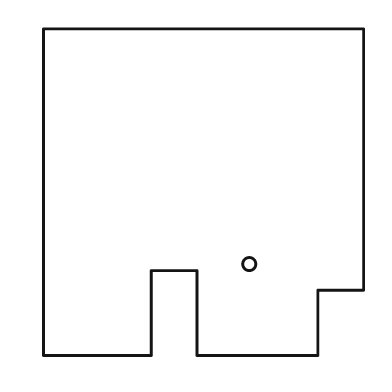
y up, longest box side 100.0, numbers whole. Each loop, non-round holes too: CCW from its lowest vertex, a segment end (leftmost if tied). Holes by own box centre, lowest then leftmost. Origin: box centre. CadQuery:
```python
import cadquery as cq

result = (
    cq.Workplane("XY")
    .moveTo(-49.0, -50.0)
    .lineTo(-16.0, -50.0)
    .lineTo(-16.0, -24.0)
    .lineTo(-2.0, -24.0)
    .lineTo(-2.0, -50.0)
    .lineTo(35.0, -50.0)
    .lineTo(35.0, -30.0)
    .lineTo(49.0, -30.0)
    .lineTo(49.0, 50.0)
    .lineTo(-49.0, 50.0)
    .close()
    .moveTo(14.0, -22.0)
    .circle(2.0)
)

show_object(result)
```